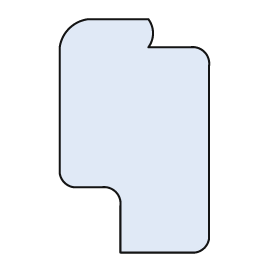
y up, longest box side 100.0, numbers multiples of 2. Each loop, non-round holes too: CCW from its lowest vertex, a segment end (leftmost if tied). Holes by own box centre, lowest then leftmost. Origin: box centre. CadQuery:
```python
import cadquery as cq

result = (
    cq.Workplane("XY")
    .moveTo(-6.0, -50.0)
    .lineTo(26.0, -50.0)
    .threePointArc((30.0, -48.0), (32.0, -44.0))
    .lineTo(32.0, 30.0)
    .threePointArc((30.0, 36.0), (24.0, 38.0))
    .lineTo(6.0, 38.0)
    .threePointArc((8.0, 44.0), (6.0, 50.0))
    .lineTo(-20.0, 50.0)
    .threePointArc((-28.0, 46.0), (-32.0, 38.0))
    .lineTo(-32.0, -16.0)
    .threePointArc((-30.0, -20.0), (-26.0, -22.0))
    .lineTo(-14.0, -22.0)
    .threePointArc((-8.0, -24.0), (-6.0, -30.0))
    .close()
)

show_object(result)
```